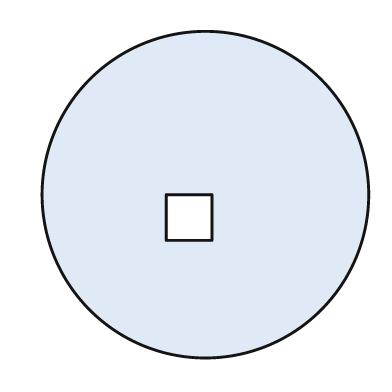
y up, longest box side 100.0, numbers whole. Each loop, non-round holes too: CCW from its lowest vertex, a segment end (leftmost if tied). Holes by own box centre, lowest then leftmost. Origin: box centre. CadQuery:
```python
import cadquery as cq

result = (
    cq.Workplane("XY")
    .moveTo(0.0, 0.0)
    .circle(50.0)
    .moveTo(-12.0, -14.0)
    .lineTo(2.0, -14.0)
    .lineTo(2.0, 0.0)
    .lineTo(-12.0, 0.0)
    .close()
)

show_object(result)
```